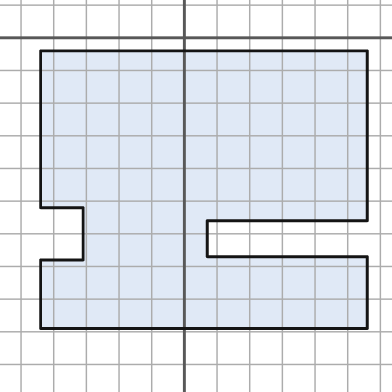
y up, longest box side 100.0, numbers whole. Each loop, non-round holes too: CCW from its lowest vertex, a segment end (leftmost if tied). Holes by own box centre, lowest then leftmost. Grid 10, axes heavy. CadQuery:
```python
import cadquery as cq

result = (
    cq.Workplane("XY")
    .moveTo(-44.0, -89.0)
    .lineTo(56.0, -89.0)
    .lineTo(56.0, -67.0)
    .lineTo(7.0, -67.0)
    .lineTo(7.0, -56.0)
    .lineTo(56.0, -56.0)
    .lineTo(56.0, -4.0)
    .lineTo(-44.0, -4.0)
    .lineTo(-44.0, -52.0)
    .lineTo(-31.0, -52.0)
    .lineTo(-31.0, -68.0)
    .lineTo(-44.0, -68.0)
    .close()
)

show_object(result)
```